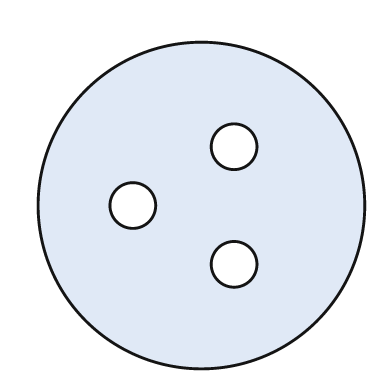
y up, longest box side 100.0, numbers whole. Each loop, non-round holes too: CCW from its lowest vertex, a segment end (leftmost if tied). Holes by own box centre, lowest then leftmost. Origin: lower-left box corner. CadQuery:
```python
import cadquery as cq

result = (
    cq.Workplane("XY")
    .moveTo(50.0, 50.0)
    .circle(50.0)
    .moveTo(60.0, 32.0)
    .circle(7.0)
    .moveTo(29.0, 50.0)
    .circle(7.0)
    .moveTo(60.0, 68.0)
    .circle(7.0)
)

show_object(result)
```